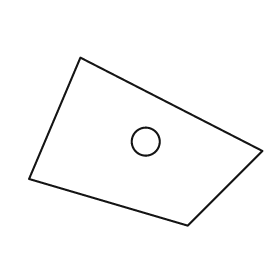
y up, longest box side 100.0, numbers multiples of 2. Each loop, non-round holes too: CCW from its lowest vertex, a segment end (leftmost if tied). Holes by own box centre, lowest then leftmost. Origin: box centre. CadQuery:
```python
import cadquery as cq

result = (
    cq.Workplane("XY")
    .moveTo(18.0, -36.0)
    .lineTo(50.0, -4.0)
    .lineTo(-28.0, 36.0)
    .lineTo(-50.0, -16.0)
    .close()
    .moveTo(0.0, 0.0)
    .circle(6.0)
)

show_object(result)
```